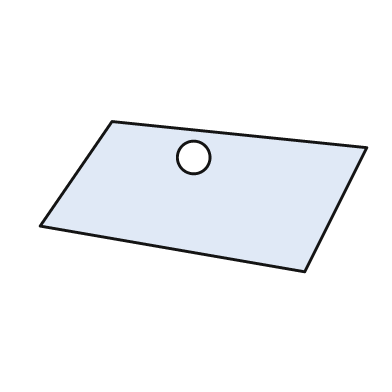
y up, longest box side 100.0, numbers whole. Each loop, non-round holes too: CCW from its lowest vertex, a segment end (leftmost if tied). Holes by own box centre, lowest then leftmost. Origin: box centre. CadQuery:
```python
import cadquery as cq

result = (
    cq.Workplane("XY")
    .moveTo(31.0, -23.0)
    .lineTo(50.0, 15.0)
    .lineTo(-28.0, 23.0)
    .lineTo(-50.0, -9.0)
    .close()
    .moveTo(-3.0, 12.0)
    .circle(5.0)
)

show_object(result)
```